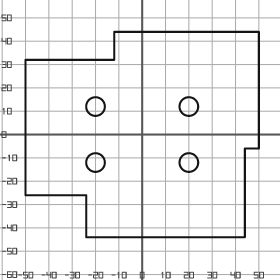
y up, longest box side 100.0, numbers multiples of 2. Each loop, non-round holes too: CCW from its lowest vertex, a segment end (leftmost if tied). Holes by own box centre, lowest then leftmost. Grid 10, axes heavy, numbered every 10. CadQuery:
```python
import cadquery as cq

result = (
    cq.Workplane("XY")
    .moveTo(-24.0, -44.0)
    .lineTo(44.0, -44.0)
    .lineTo(44.0, -6.0)
    .lineTo(50.0, -6.0)
    .lineTo(50.0, 44.0)
    .lineTo(-12.0, 44.0)
    .lineTo(-12.0, 32.0)
    .lineTo(-50.0, 32.0)
    .lineTo(-50.0, -26.0)
    .lineTo(-24.0, -26.0)
    .close()
    .moveTo(-20.0, -12.0)
    .circle(4.0)
    .moveTo(20.0, -12.0)
    .circle(4.0)
    .moveTo(-20.0, 12.0)
    .circle(4.0)
    .moveTo(20.0, 12.0)
    .circle(4.0)
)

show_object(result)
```